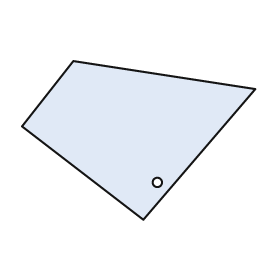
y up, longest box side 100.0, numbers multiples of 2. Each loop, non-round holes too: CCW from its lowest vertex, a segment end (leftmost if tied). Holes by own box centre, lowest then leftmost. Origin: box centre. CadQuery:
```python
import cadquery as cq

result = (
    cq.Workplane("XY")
    .moveTo(2.0, -34.0)
    .lineTo(50.0, 22.0)
    .lineTo(-28.0, 34.0)
    .lineTo(-50.0, 6.0)
    .close()
    .moveTo(8.0, -18.0)
    .circle(2.0)
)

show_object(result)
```